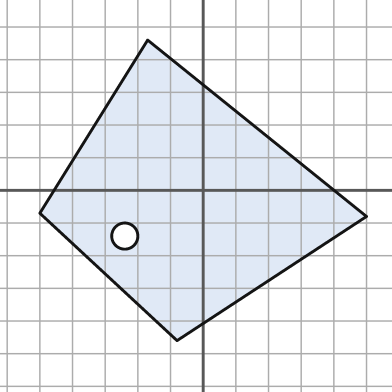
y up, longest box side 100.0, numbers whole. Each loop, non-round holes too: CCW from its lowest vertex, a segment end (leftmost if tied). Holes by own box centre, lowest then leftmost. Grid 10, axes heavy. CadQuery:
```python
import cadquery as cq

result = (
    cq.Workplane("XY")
    .moveTo(-8.0, -46.0)
    .lineTo(50.0, -8.0)
    .lineTo(-17.0, 46.0)
    .lineTo(-50.0, -7.0)
    .close()
    .moveTo(-24.0, -14.0)
    .circle(4.0)
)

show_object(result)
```